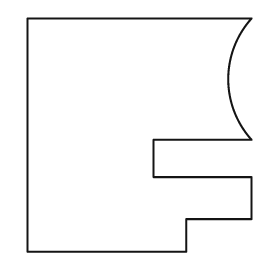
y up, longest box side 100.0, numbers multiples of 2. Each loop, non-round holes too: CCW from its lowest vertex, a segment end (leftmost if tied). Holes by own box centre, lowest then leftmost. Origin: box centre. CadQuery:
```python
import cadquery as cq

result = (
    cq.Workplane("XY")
    .moveTo(-48.0, -50.0)
    .lineTo(20.0, -50.0)
    .lineTo(20.0, -36.0)
    .lineTo(48.0, -36.0)
    .lineTo(48.0, -18.0)
    .lineTo(6.0, -18.0)
    .lineTo(6.0, -2.0)
    .lineTo(48.0, -2.0)
    .threePointArc((38.0, 24.0), (48.0, 50.0))
    .lineTo(-48.0, 50.0)
    .close()
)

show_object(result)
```